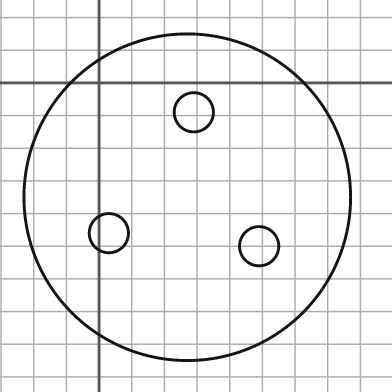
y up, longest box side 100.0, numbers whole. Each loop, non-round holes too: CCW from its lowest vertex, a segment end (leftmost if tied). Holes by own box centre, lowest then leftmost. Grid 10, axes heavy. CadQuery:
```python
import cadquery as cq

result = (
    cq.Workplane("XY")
    .moveTo(27.0, -35.0)
    .circle(50.0)
    .moveTo(49.0, -50.0)
    .circle(6.0)
    .moveTo(3.0, -46.0)
    .circle(6.0)
    .moveTo(29.0, -9.0)
    .circle(6.0)
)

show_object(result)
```